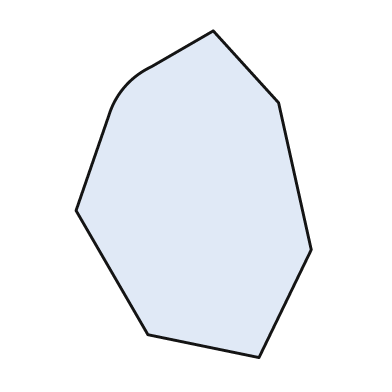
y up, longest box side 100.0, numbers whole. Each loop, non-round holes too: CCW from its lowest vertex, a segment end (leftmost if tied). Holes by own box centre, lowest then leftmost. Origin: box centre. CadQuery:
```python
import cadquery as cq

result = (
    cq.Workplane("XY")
    .moveTo(20.0, -50.0)
    .lineTo(36.0, -17.0)
    .lineTo(26.0, 28.0)
    .lineTo(6.0, 50.0)
    .lineTo(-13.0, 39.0)
    .threePointArc((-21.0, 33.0), (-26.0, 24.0))
    .lineTo(-36.0, -5.0)
    .lineTo(-14.0, -43.0)
    .close()
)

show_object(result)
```